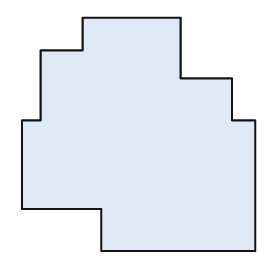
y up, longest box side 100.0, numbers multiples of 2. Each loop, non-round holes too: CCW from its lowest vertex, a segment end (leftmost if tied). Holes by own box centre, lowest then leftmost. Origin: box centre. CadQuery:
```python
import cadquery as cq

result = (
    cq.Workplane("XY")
    .moveTo(-16.0, -50.0)
    .lineTo(50.0, -50.0)
    .lineTo(50.0, 6.0)
    .lineTo(40.0, 6.0)
    .lineTo(40.0, 24.0)
    .lineTo(18.0, 24.0)
    .lineTo(18.0, 50.0)
    .lineTo(-24.0, 50.0)
    .lineTo(-24.0, 36.0)
    .lineTo(-42.0, 36.0)
    .lineTo(-42.0, 6.0)
    .lineTo(-50.0, 6.0)
    .lineTo(-50.0, -32.0)
    .lineTo(-16.0, -32.0)
    .close()
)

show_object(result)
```